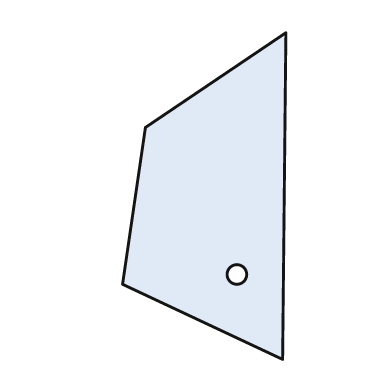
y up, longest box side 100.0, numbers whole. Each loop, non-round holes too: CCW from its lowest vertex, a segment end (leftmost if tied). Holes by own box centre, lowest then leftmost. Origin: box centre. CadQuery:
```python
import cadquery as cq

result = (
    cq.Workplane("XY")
    .moveTo(24.0, -50.0)
    .lineTo(25.0, 50.0)
    .lineTo(-18.0, 21.0)
    .lineTo(-25.0, -27.0)
    .close()
    .moveTo(10.0, -24.0)
    .circle(3.0)
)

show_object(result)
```